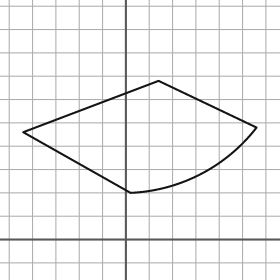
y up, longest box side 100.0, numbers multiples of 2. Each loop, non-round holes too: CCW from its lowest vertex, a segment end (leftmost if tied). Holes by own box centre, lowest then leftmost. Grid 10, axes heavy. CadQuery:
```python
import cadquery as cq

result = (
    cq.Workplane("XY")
    .moveTo(2.0, 20.0)
    .threePointArc((32.0, 28.0), (56.0, 48.0))
    .lineTo(14.0, 68.0)
    .lineTo(-44.0, 46.0)
    .close()
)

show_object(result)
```